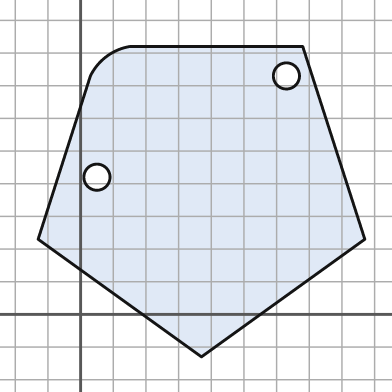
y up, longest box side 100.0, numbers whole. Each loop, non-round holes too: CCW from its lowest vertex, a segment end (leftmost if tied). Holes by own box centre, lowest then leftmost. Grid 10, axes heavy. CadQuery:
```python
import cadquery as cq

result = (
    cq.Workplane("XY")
    .moveTo(37.0, -13.0)
    .lineTo(87.0, 23.0)
    .lineTo(68.0, 82.0)
    .lineTo(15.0, 82.0)
    .threePointArc((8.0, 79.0), (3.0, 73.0))
    .lineTo(-13.0, 23.0)
    .close()
    .moveTo(5.0, 42.0)
    .circle(4.0)
    .moveTo(63.0, 73.0)
    .circle(4.0)
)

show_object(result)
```